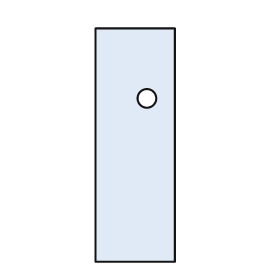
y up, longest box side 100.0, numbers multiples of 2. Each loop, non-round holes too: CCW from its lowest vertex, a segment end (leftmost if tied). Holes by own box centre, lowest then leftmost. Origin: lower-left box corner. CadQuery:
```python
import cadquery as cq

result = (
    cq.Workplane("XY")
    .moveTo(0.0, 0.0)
    .lineTo(34.0, 0.0)
    .lineTo(34.0, 100.0)
    .lineTo(0.0, 100.0)
    .close()
    .moveTo(22.0, 70.0)
    .circle(4.0)
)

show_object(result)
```